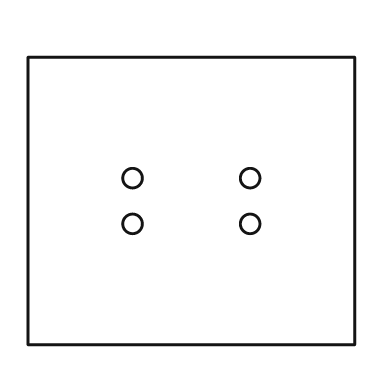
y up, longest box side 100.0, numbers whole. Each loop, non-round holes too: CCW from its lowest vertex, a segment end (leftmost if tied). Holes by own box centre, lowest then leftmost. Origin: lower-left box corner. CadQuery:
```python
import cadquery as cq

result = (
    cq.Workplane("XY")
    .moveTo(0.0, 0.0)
    .lineTo(100.0, 0.0)
    .lineTo(100.0, 88.0)
    .lineTo(0.0, 88.0)
    .close()
    .moveTo(32.0, 37.0)
    .circle(3.0)
    .moveTo(68.0, 37.0)
    .circle(3.0)
    .moveTo(32.0, 51.0)
    .circle(3.0)
    .moveTo(68.0, 51.0)
    .circle(3.0)
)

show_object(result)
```